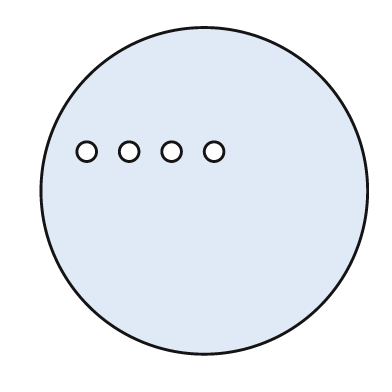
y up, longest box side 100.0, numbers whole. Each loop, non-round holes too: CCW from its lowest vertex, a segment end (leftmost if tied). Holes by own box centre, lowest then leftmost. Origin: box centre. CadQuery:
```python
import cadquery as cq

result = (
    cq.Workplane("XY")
    .moveTo(0.0, 0.0)
    .circle(50.0)
    .moveTo(-36.0, 12.0)
    .circle(3.0)
    .moveTo(-23.0, 12.0)
    .circle(3.0)
    .moveTo(-10.0, 12.0)
    .circle(3.0)
    .moveTo(3.0, 12.0)
    .circle(3.0)
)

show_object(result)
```